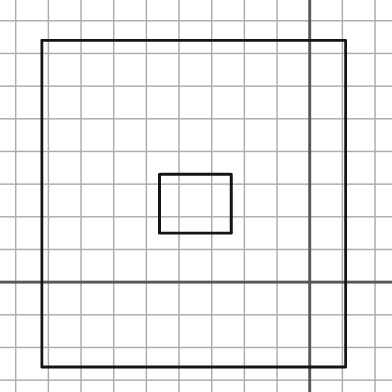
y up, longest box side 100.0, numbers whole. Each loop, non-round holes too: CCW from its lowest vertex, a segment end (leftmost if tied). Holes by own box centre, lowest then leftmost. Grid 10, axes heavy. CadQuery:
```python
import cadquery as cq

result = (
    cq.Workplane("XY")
    .moveTo(-82.0, -26.0)
    .lineTo(11.0, -26.0)
    .lineTo(11.0, 74.0)
    .lineTo(-82.0, 74.0)
    .close()
    .moveTo(-46.0, 15.0)
    .lineTo(-24.0, 15.0)
    .lineTo(-24.0, 33.0)
    .lineTo(-46.0, 33.0)
    .close()
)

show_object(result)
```